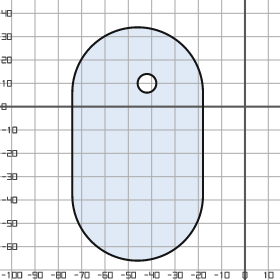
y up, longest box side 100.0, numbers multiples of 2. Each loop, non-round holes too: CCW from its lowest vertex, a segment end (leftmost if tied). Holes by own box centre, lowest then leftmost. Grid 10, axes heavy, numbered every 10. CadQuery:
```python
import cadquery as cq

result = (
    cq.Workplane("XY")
    .moveTo(-74.0, -38.0)
    .threePointArc((-46.0, -66.0), (-18.0, -38.0))
    .lineTo(-18.0, 6.0)
    .threePointArc((-46.0, 34.0), (-74.0, 6.0))
    .close()
    .moveTo(-42.0, 10.0)
    .circle(4.0)
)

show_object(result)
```